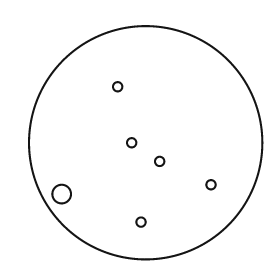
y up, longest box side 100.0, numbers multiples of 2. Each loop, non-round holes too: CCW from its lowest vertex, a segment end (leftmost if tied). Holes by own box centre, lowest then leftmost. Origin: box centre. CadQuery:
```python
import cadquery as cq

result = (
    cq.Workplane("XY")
    .moveTo(0.0, 0.0)
    .circle(50.0)
    .moveTo(-2.0, -34.0)
    .circle(2.0)
    .moveTo(-36.0, -22.0)
    .circle(4.0)
    .moveTo(28.0, -18.0)
    .circle(2.0)
    .moveTo(6.0, -8.0)
    .circle(2.0)
    .moveTo(-6.0, 0.0)
    .circle(2.0)
    .moveTo(-12.0, 24.0)
    .circle(2.0)
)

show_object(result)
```